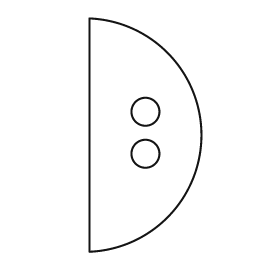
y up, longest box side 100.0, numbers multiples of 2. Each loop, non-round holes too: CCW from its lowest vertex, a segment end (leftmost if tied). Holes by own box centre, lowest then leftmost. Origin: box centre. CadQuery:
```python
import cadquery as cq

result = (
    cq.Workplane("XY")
    .moveTo(-24.0, -50.0)
    .threePointArc((24.0, 0.0), (-24.0, 50.0))
    .close()
    .moveTo(0.0, -8.0)
    .circle(6.0)
    .moveTo(0.0, 10.0)
    .circle(6.0)
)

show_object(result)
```